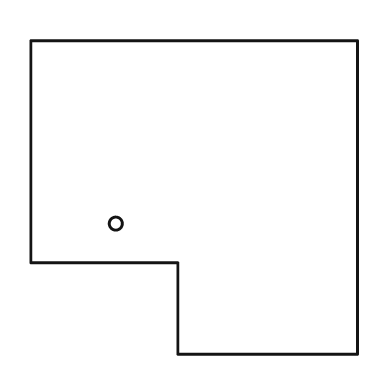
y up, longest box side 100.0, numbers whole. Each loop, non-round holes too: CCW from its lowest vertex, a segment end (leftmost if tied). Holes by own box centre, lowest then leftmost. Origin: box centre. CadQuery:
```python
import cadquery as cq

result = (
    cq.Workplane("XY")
    .moveTo(-5.0, -48.0)
    .lineTo(50.0, -48.0)
    .lineTo(50.0, 48.0)
    .lineTo(-50.0, 48.0)
    .lineTo(-50.0, -20.0)
    .lineTo(-5.0, -20.0)
    .close()
    .moveTo(-24.0, -8.0)
    .circle(2.0)
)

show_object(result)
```